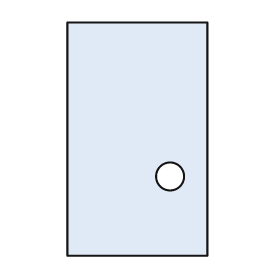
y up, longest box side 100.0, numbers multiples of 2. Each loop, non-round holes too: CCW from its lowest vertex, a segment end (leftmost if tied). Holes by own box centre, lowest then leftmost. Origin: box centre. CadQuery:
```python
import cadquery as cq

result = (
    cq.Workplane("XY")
    .moveTo(-30.0, -50.0)
    .lineTo(30.0, -50.0)
    .lineTo(30.0, 50.0)
    .lineTo(-30.0, 50.0)
    .close()
    .moveTo(14.0, -16.0)
    .circle(6.0)
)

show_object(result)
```